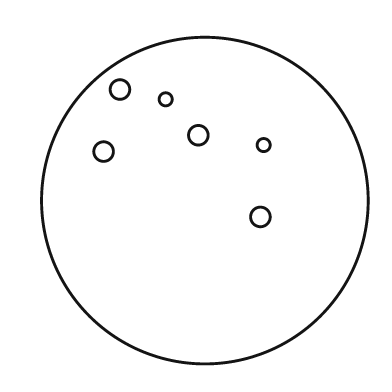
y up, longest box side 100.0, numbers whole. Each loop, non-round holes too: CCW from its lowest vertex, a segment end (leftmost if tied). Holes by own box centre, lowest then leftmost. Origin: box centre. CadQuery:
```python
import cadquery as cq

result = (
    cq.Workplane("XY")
    .moveTo(0.0, 0.0)
    .circle(50.0)
    .moveTo(17.0, -5.0)
    .circle(3.0)
    .moveTo(-31.0, 15.0)
    .circle(3.0)
    .moveTo(18.0, 17.0)
    .circle(2.0)
    .moveTo(-2.0, 20.0)
    .circle(3.0)
    .moveTo(-12.0, 31.0)
    .circle(2.0)
    .moveTo(-26.0, 34.0)
    .circle(3.0)
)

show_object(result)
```